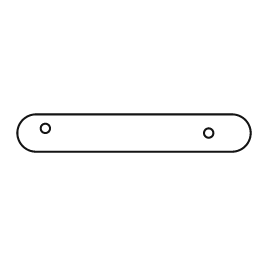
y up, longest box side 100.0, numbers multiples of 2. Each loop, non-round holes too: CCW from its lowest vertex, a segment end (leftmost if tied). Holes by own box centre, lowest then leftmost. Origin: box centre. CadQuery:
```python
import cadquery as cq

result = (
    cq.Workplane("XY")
    .moveTo(-42.0, -8.0)
    .lineTo(42.0, -8.0)
    .threePointArc((50.0, 0.0), (42.0, 8.0))
    .lineTo(-42.0, 8.0)
    .threePointArc((-50.0, 0.0), (-42.0, -8.0))
    .close()
    .moveTo(32.0, 0.0)
    .circle(2.0)
    .moveTo(-38.0, 2.0)
    .circle(2.0)
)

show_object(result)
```